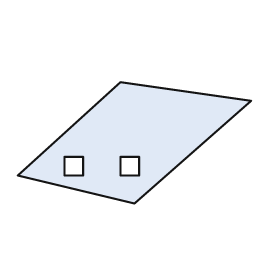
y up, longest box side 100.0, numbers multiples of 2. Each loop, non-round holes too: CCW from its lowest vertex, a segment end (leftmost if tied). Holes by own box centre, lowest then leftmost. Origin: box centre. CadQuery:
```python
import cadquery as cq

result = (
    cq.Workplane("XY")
    .moveTo(0.0, -26.0)
    .lineTo(50.0, 18.0)
    .lineTo(-6.0, 26.0)
    .lineTo(-50.0, -14.0)
    .close()
    .moveTo(-30.0, -14.0)
    .lineTo(-22.0, -14.0)
    .lineTo(-22.0, -6.0)
    .lineTo(-30.0, -6.0)
    .close()
    .moveTo(-6.0, -14.0)
    .lineTo(2.0, -14.0)
    .lineTo(2.0, -6.0)
    .lineTo(-6.0, -6.0)
    .close()
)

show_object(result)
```